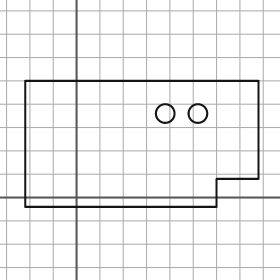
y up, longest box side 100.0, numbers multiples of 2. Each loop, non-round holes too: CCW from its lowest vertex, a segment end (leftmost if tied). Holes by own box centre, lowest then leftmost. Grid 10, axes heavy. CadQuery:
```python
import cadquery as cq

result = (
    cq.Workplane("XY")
    .moveTo(-22.0, -4.0)
    .lineTo(60.0, -4.0)
    .lineTo(60.0, 8.0)
    .lineTo(78.0, 8.0)
    .lineTo(78.0, 50.0)
    .lineTo(-22.0, 50.0)
    .close()
    .moveTo(38.0, 36.0)
    .circle(4.0)
    .moveTo(52.0, 36.0)
    .circle(4.0)
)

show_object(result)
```